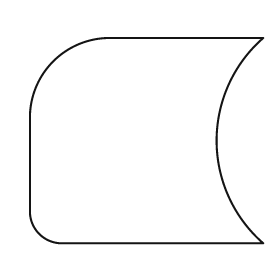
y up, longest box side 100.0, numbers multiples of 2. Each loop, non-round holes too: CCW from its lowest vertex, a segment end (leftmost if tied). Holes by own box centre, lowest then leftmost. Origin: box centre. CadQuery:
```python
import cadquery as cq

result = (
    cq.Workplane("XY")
    .moveTo(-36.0, -44.0)
    .lineTo(50.0, -44.0)
    .threePointArc((30.0, 0.0), (50.0, 44.0))
    .lineTo(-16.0, 44.0)
    .threePointArc((-40.0, 34.0), (-50.0, 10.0))
    .lineTo(-50.0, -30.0)
    .threePointArc((-46.0, -40.0), (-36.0, -44.0))
    .close()
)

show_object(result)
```